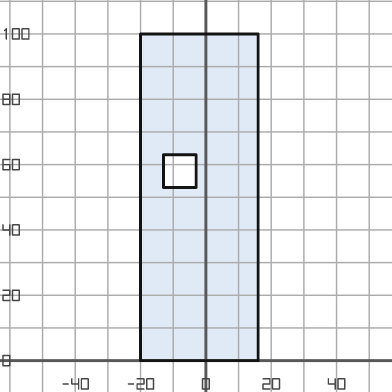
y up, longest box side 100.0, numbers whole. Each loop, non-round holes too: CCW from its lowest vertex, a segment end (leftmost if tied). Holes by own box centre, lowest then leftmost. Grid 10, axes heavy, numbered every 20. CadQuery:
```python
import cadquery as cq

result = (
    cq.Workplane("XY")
    .moveTo(-20.0, 0.0)
    .lineTo(16.0, 0.0)
    .lineTo(16.0, 100.0)
    .lineTo(-20.0, 100.0)
    .close()
    .moveTo(-13.0, 53.0)
    .lineTo(-3.0, 53.0)
    .lineTo(-3.0, 63.0)
    .lineTo(-13.0, 63.0)
    .close()
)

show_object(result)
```